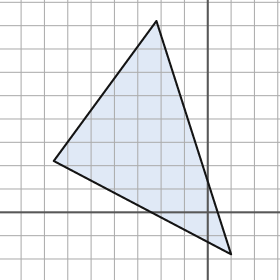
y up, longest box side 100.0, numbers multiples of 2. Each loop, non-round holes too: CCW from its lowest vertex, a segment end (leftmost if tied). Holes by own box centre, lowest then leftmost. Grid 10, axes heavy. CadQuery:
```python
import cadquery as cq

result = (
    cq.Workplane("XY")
    .moveTo(10.0, -18.0)
    .lineTo(-22.0, 82.0)
    .lineTo(-66.0, 22.0)
    .close()
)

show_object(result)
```